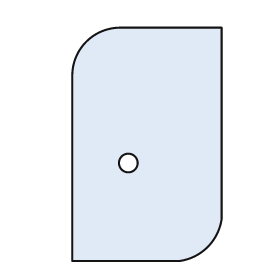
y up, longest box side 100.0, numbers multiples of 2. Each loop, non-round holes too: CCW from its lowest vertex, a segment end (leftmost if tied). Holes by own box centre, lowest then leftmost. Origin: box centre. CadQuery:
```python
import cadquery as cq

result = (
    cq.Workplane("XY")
    .moveTo(-32.0, -50.0)
    .lineTo(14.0, -50.0)
    .threePointArc((26.0, -44.0), (32.0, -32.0))
    .lineTo(32.0, 50.0)
    .lineTo(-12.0, 50.0)
    .threePointArc((-26.0, 44.0), (-32.0, 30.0))
    .close()
    .moveTo(-8.0, -8.0)
    .circle(4.0)
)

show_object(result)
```